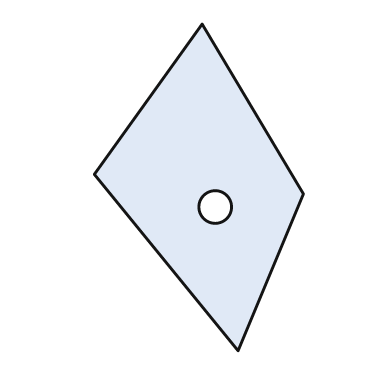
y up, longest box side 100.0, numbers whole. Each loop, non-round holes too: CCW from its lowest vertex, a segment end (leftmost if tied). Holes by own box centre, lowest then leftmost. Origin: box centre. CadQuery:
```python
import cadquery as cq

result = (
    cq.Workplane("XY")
    .moveTo(12.0, -50.0)
    .lineTo(32.0, -2.0)
    .lineTo(1.0, 50.0)
    .lineTo(-32.0, 4.0)
    .close()
    .moveTo(5.0, -6.0)
    .circle(5.0)
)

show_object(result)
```